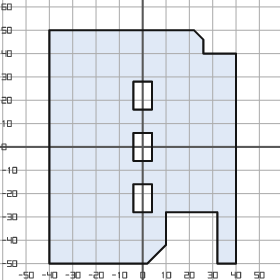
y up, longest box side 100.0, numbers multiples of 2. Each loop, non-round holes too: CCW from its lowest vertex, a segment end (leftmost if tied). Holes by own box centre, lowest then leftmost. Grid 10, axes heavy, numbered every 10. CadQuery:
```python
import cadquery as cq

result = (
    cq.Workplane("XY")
    .moveTo(-40.0, -50.0)
    .lineTo(2.0, -50.0)
    .lineTo(10.0, -42.0)
    .lineTo(10.0, -28.0)
    .lineTo(32.0, -28.0)
    .lineTo(32.0, -50.0)
    .lineTo(40.0, -50.0)
    .lineTo(40.0, 40.0)
    .lineTo(26.0, 40.0)
    .lineTo(26.0, 46.0)
    .lineTo(22.0, 50.0)
    .lineTo(-40.0, 50.0)
    .close()
    .moveTo(-4.0, -28.0)
    .lineTo(4.0, -28.0)
    .lineTo(4.0, -16.0)
    .lineTo(-4.0, -16.0)
    .close()
    .moveTo(-4.0, -6.0)
    .lineTo(4.0, -6.0)
    .lineTo(4.0, 6.0)
    .lineTo(-4.0, 6.0)
    .close()
    .moveTo(-4.0, 16.0)
    .lineTo(4.0, 16.0)
    .lineTo(4.0, 28.0)
    .lineTo(-4.0, 28.0)
    .close()
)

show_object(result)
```